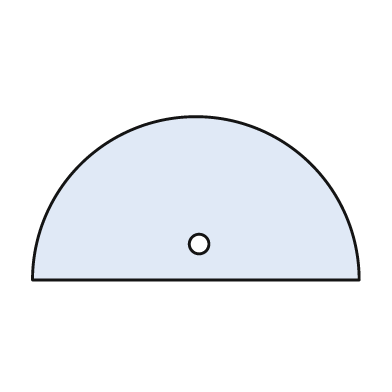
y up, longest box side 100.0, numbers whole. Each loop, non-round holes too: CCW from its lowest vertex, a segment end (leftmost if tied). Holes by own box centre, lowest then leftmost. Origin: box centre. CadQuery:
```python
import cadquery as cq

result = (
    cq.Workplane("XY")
    .moveTo(-50.0, -25.0)
    .lineTo(50.0, -25.0)
    .threePointArc((0.0, 25.0), (-50.0, -25.0))
    .close()
    .moveTo(1.0, -14.0)
    .circle(3.0)
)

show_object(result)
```